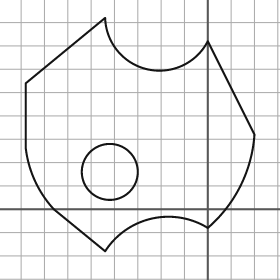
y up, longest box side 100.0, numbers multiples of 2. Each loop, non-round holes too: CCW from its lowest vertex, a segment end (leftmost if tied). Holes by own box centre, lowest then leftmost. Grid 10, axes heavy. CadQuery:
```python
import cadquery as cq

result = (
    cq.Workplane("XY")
    .moveTo(-44.0, -18.0)
    .threePointArc((-24.0, -4.0), (0.0, -8.0))
    .threePointArc((14.0, 10.0), (20.0, 32.0))
    .lineTo(0.0, 72.0)
    .threePointArc((-26.0, 60.0), (-44.0, 82.0))
    .lineTo(-78.0, 54.0)
    .lineTo(-78.0, 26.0)
    .threePointArc((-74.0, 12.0), (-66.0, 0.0))
    .close()
    .moveTo(-42.0, 16.0)
    .circle(12.0)
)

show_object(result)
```